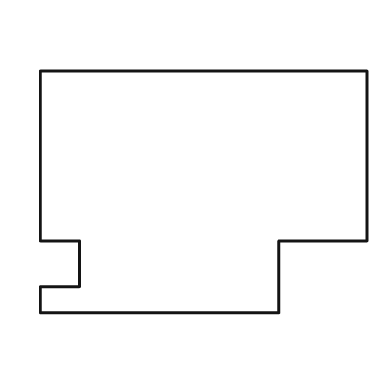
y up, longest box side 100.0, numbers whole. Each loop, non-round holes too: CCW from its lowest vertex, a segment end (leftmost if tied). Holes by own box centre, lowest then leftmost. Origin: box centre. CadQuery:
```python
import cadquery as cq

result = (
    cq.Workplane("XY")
    .moveTo(-50.0, -37.0)
    .lineTo(23.0, -37.0)
    .lineTo(23.0, -15.0)
    .lineTo(50.0, -15.0)
    .lineTo(50.0, 37.0)
    .lineTo(-50.0, 37.0)
    .lineTo(-50.0, -15.0)
    .lineTo(-38.0, -15.0)
    .lineTo(-38.0, -29.0)
    .lineTo(-50.0, -29.0)
    .close()
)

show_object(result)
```